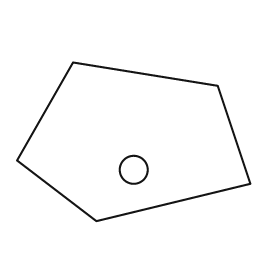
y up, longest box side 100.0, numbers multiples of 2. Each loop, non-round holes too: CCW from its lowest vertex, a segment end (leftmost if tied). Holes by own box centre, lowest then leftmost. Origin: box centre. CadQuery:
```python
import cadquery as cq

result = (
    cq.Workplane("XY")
    .moveTo(-16.0, -34.0)
    .lineTo(50.0, -18.0)
    .lineTo(36.0, 24.0)
    .lineTo(-26.0, 34.0)
    .lineTo(-50.0, -8.0)
    .close()
    .moveTo(0.0, -12.0)
    .circle(6.0)
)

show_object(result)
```